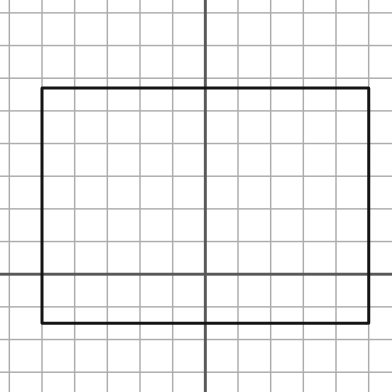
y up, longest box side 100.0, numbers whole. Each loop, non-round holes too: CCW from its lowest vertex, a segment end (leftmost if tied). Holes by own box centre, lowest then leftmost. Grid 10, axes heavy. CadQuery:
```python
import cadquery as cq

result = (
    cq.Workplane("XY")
    .moveTo(-50.0, -15.0)
    .lineTo(50.0, -15.0)
    .lineTo(50.0, 57.0)
    .lineTo(-50.0, 57.0)
    .close()
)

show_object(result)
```